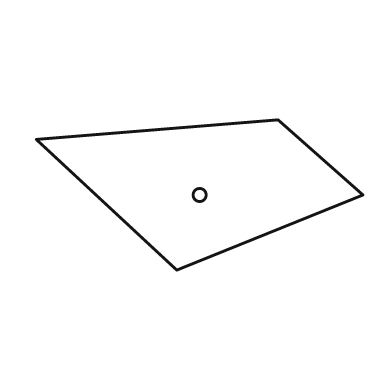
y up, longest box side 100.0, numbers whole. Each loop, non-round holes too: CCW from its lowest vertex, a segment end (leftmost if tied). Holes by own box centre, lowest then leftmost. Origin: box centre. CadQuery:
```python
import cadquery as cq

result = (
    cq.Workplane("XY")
    .moveTo(-7.0, -23.0)
    .lineTo(50.0, 0.0)
    .lineTo(24.0, 23.0)
    .lineTo(-50.0, 17.0)
    .close()
    .moveTo(0.0, 0.0)
    .circle(2.0)
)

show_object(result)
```